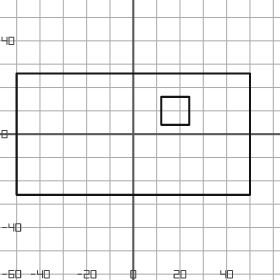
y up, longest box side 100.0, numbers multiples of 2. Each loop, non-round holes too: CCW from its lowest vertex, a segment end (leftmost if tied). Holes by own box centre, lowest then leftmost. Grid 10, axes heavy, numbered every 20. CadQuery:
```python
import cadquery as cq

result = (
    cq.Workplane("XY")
    .moveTo(-50.0, -26.0)
    .lineTo(50.0, -26.0)
    .lineTo(50.0, 26.0)
    .lineTo(-50.0, 26.0)
    .close()
    .moveTo(12.0, 4.0)
    .lineTo(24.0, 4.0)
    .lineTo(24.0, 16.0)
    .lineTo(12.0, 16.0)
    .close()
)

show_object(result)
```